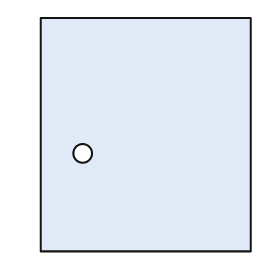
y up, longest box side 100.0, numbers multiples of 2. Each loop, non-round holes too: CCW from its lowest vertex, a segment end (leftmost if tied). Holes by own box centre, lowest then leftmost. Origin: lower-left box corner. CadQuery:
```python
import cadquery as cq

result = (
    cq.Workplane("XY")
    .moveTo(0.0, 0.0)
    .lineTo(90.0, 0.0)
    .lineTo(90.0, 100.0)
    .lineTo(0.0, 100.0)
    .close()
    .moveTo(18.0, 42.0)
    .circle(4.0)
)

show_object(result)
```